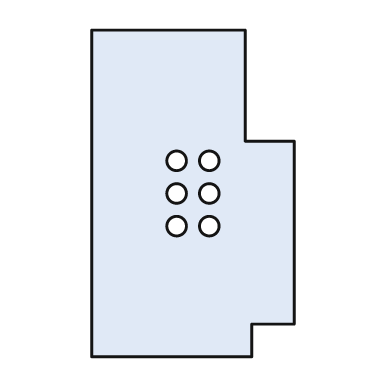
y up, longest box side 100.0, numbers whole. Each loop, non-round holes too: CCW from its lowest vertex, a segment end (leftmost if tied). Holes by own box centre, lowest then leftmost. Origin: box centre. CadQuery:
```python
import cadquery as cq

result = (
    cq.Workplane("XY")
    .moveTo(-31.0, -50.0)
    .lineTo(18.0, -50.0)
    .lineTo(18.0, -40.0)
    .lineTo(31.0, -40.0)
    .lineTo(31.0, 16.0)
    .lineTo(16.0, 16.0)
    .lineTo(16.0, 50.0)
    .lineTo(-31.0, 50.0)
    .close()
    .moveTo(-5.0, -10.0)
    .circle(3.0)
    .moveTo(5.0, -10.0)
    .circle(3.0)
    .moveTo(-5.0, 0.0)
    .circle(3.0)
    .moveTo(5.0, 0.0)
    .circle(3.0)
    .moveTo(-5.0, 10.0)
    .circle(3.0)
    .moveTo(5.0, 10.0)
    .circle(3.0)
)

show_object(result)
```